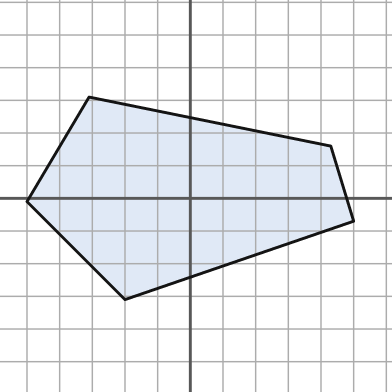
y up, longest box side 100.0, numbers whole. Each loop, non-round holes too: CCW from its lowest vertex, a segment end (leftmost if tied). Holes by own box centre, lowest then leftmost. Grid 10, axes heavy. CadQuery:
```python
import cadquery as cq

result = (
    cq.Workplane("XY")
    .moveTo(-20.0, -31.0)
    .lineTo(50.0, -7.0)
    .lineTo(43.0, 16.0)
    .lineTo(-31.0, 31.0)
    .lineTo(-50.0, -1.0)
    .close()
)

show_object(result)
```